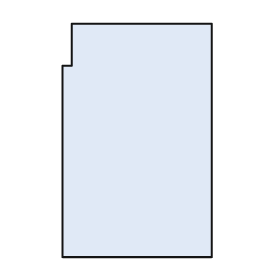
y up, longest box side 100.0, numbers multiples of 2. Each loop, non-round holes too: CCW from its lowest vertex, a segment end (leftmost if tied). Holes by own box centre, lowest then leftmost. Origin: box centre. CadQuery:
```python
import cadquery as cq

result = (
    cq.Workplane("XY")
    .moveTo(-32.0, -50.0)
    .lineTo(32.0, -50.0)
    .lineTo(32.0, 50.0)
    .lineTo(-28.0, 50.0)
    .lineTo(-28.0, 32.0)
    .lineTo(-32.0, 32.0)
    .close()
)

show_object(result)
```